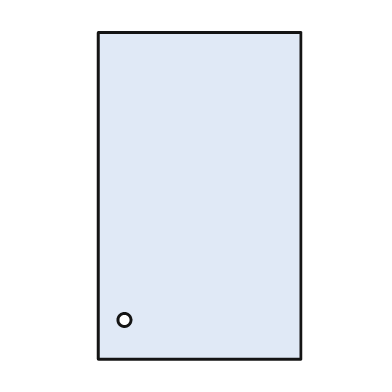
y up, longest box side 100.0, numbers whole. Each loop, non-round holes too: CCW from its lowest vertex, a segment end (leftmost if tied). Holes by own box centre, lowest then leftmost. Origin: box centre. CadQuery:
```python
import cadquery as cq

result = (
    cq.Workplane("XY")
    .moveTo(-31.0, -50.0)
    .lineTo(31.0, -50.0)
    .lineTo(31.0, 50.0)
    .lineTo(-31.0, 50.0)
    .close()
    .moveTo(-23.0, -38.0)
    .circle(2.0)
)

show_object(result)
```